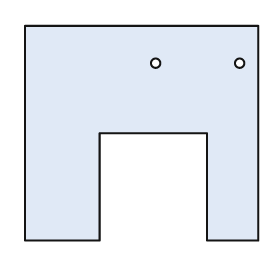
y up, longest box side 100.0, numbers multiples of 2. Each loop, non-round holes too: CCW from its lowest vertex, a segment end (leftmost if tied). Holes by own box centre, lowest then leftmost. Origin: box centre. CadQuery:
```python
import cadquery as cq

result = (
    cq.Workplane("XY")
    .moveTo(-50.0, -46.0)
    .lineTo(-18.0, -46.0)
    .lineTo(-18.0, 0.0)
    .lineTo(28.0, 0.0)
    .lineTo(28.0, -46.0)
    .lineTo(50.0, -46.0)
    .lineTo(50.0, 46.0)
    .lineTo(-50.0, 46.0)
    .close()
    .moveTo(6.0, 30.0)
    .circle(2.0)
    .moveTo(42.0, 30.0)
    .circle(2.0)
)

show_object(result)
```